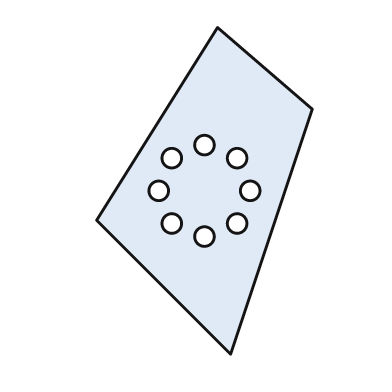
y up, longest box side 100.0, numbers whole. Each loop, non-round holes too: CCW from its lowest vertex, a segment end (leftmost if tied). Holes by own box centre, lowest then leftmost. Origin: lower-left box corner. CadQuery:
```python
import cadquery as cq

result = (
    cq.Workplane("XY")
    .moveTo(41.0, 0.0)
    .lineTo(66.0, 75.0)
    .lineTo(37.0, 100.0)
    .lineTo(0.0, 41.0)
    .close()
    .moveTo(33.0, 36.0)
    .circle(3.0)
    .moveTo(23.0, 40.0)
    .circle(3.0)
    .moveTo(43.0, 40.0)
    .circle(3.0)
    .moveTo(19.0, 50.0)
    .circle(3.0)
    .moveTo(47.0, 50.0)
    .circle(3.0)
    .moveTo(23.0, 60.0)
    .circle(3.0)
    .moveTo(43.0, 60.0)
    .circle(3.0)
    .moveTo(33.0, 64.0)
    .circle(3.0)
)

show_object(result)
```